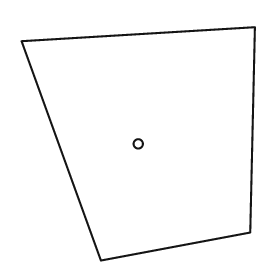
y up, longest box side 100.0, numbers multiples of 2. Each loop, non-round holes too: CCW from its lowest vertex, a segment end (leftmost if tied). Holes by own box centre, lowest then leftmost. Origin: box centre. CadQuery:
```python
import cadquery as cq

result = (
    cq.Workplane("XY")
    .moveTo(-16.0, -50.0)
    .lineTo(48.0, -38.0)
    .lineTo(50.0, 50.0)
    .lineTo(-50.0, 44.0)
    .close()
    .moveTo(0.0, 0.0)
    .circle(2.0)
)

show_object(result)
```